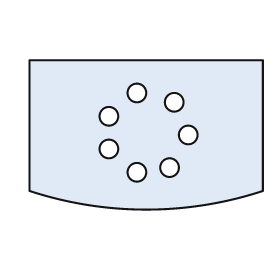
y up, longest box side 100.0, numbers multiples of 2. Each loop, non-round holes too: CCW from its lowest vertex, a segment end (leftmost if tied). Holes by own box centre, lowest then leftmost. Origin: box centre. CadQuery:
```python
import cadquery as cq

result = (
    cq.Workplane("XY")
    .moveTo(-50.0, -24.0)
    .threePointArc((0.0, -32.0), (50.0, -24.0))
    .lineTo(50.0, 32.0)
    .lineTo(-50.0, 32.0)
    .close()
    .moveTo(-4.0, -16.0)
    .circle(4.0)
    .moveTo(10.0, -14.0)
    .circle(4.0)
    .moveTo(-16.0, -6.0)
    .circle(4.0)
    .moveTo(18.0, 0.0)
    .circle(4.0)
    .moveTo(-16.0, 8.0)
    .circle(4.0)
    .moveTo(12.0, 14.0)
    .circle(4.0)
    .moveTo(-4.0, 18.0)
    .circle(4.0)
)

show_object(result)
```